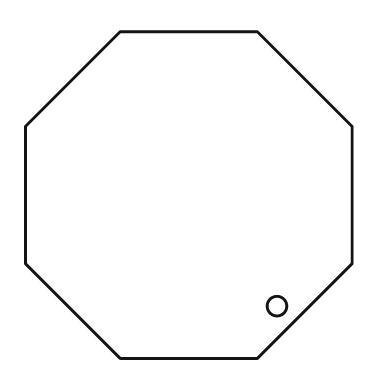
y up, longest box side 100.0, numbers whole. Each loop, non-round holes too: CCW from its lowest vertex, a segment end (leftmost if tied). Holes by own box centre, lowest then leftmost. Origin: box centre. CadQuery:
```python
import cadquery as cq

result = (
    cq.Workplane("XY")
    .moveTo(-21.0, -50.0)
    .lineTo(21.0, -50.0)
    .lineTo(50.0, -21.0)
    .lineTo(50.0, 21.0)
    .lineTo(21.0, 50.0)
    .lineTo(-21.0, 50.0)
    .lineTo(-50.0, 21.0)
    .lineTo(-50.0, -21.0)
    .close()
    .moveTo(27.0, -34.0)
    .circle(3.0)
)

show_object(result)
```